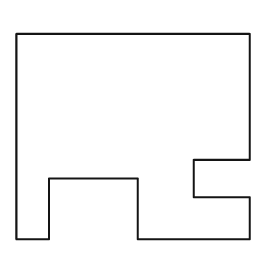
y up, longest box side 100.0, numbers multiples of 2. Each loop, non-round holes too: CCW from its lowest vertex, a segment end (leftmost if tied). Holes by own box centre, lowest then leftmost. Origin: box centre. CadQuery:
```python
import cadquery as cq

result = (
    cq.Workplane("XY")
    .moveTo(-50.0, -44.0)
    .lineTo(-36.0, -44.0)
    .lineTo(-36.0, -18.0)
    .lineTo(2.0, -18.0)
    .lineTo(2.0, -44.0)
    .lineTo(50.0, -44.0)
    .lineTo(50.0, -26.0)
    .lineTo(26.0, -26.0)
    .lineTo(26.0, -10.0)
    .lineTo(50.0, -10.0)
    .lineTo(50.0, 44.0)
    .lineTo(-50.0, 44.0)
    .close()
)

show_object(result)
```